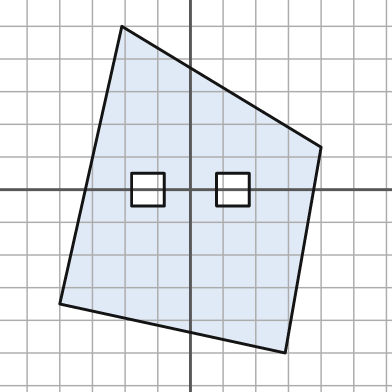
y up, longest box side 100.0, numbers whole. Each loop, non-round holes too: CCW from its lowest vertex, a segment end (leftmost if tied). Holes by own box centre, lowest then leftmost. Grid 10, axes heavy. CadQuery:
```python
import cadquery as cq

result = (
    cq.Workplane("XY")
    .moveTo(29.0, -50.0)
    .lineTo(40.0, 13.0)
    .lineTo(-21.0, 50.0)
    .lineTo(-40.0, -35.0)
    .close()
    .moveTo(-18.0, -5.0)
    .lineTo(-8.0, -5.0)
    .lineTo(-8.0, 5.0)
    .lineTo(-18.0, 5.0)
    .close()
    .moveTo(8.0, -5.0)
    .lineTo(18.0, -5.0)
    .lineTo(18.0, 5.0)
    .lineTo(8.0, 5.0)
    .close()
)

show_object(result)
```